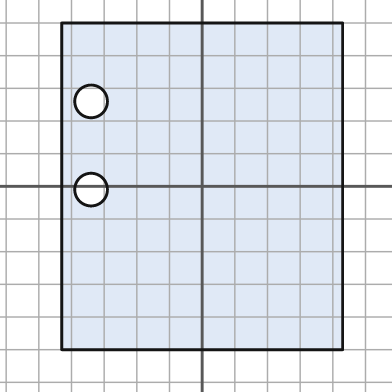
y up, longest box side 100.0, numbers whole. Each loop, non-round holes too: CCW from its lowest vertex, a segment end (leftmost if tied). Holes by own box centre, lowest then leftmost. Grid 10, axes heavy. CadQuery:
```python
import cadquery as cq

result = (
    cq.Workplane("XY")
    .moveTo(-43.0, -50.0)
    .lineTo(43.0, -50.0)
    .lineTo(43.0, 50.0)
    .lineTo(-43.0, 50.0)
    .close()
    .moveTo(-34.0, -1.0)
    .circle(5.0)
    .moveTo(-34.0, 26.0)
    .circle(5.0)
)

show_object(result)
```